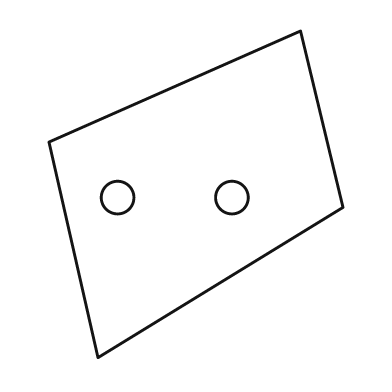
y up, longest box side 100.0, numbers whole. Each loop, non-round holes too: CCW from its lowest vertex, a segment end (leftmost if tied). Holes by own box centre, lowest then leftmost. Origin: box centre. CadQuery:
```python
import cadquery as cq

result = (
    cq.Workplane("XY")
    .moveTo(-30.0, -50.0)
    .lineTo(45.0, -4.0)
    .lineTo(32.0, 50.0)
    .lineTo(-45.0, 16.0)
    .close()
    .moveTo(-24.0, -1.0)
    .circle(5.0)
    .moveTo(11.0, -1.0)
    .circle(5.0)
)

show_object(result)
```